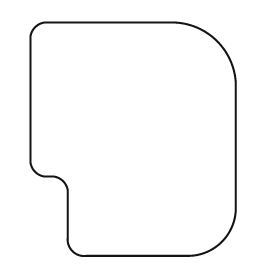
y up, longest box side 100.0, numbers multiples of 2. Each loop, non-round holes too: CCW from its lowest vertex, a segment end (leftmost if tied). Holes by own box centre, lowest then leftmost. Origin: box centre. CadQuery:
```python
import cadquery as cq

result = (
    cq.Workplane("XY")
    .moveTo(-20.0, -50.0)
    .lineTo(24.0, -50.0)
    .threePointArc((38.0, -44.0), (44.0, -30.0))
    .lineTo(44.0, 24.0)
    .threePointArc((36.0, 42.0), (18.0, 50.0))
    .lineTo(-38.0, 50.0)
    .threePointArc((-42.0, 48.0), (-44.0, 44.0))
    .lineTo(-44.0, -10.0)
    .threePointArc((-42.0, -14.0), (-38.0, -16.0))
    .lineTo(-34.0, -16.0)
    .threePointArc((-30.0, -18.0), (-28.0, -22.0))
    .lineTo(-28.0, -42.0)
    .threePointArc((-26.0, -48.0), (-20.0, -50.0))
    .close()
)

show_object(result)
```